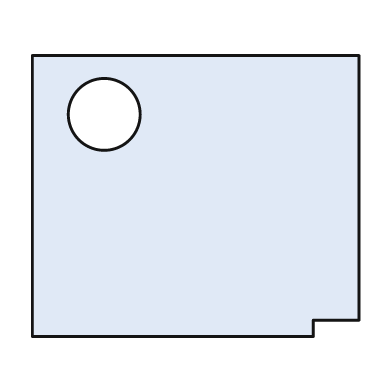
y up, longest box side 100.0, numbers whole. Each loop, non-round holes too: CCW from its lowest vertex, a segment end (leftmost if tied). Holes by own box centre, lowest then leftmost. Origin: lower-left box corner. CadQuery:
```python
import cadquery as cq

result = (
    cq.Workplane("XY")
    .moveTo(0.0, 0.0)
    .lineTo(86.0, 0.0)
    .lineTo(86.0, 5.0)
    .lineTo(100.0, 5.0)
    .lineTo(100.0, 86.0)
    .lineTo(0.0, 86.0)
    .close()
    .moveTo(22.0, 68.0)
    .circle(11.0)
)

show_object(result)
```